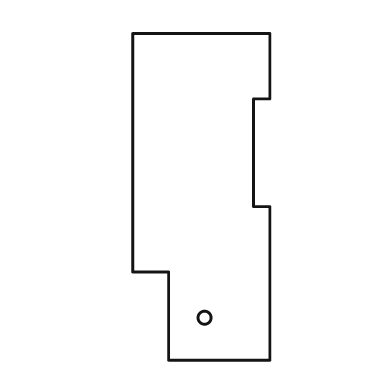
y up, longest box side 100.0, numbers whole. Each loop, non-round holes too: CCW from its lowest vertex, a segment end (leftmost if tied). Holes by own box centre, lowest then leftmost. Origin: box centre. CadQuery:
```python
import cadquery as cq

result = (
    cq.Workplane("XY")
    .moveTo(-10.0, -50.0)
    .lineTo(21.0, -50.0)
    .lineTo(21.0, -3.0)
    .lineTo(16.0, -3.0)
    .lineTo(16.0, 30.0)
    .lineTo(21.0, 30.0)
    .lineTo(21.0, 50.0)
    .lineTo(-21.0, 50.0)
    .lineTo(-21.0, -23.0)
    .lineTo(-10.0, -23.0)
    .close()
    .moveTo(1.0, -37.0)
    .circle(2.0)
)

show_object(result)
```